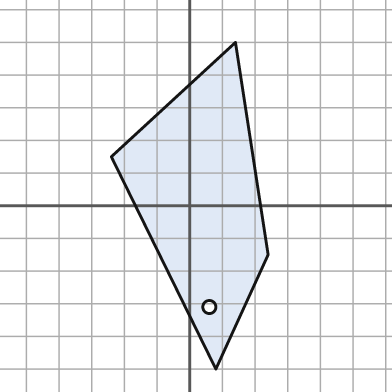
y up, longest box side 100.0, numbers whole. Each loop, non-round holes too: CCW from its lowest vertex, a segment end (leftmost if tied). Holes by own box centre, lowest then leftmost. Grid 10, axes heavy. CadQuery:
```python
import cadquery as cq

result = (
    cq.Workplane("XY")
    .moveTo(8.0, -50.0)
    .lineTo(24.0, -15.0)
    .lineTo(14.0, 50.0)
    .lineTo(-24.0, 15.0)
    .close()
    .moveTo(6.0, -31.0)
    .circle(2.0)
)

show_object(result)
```